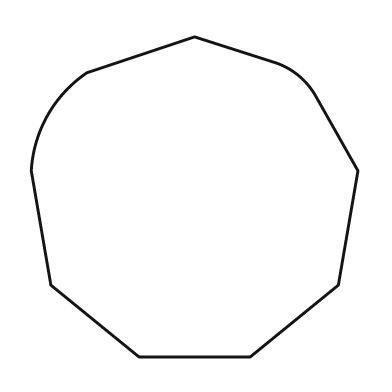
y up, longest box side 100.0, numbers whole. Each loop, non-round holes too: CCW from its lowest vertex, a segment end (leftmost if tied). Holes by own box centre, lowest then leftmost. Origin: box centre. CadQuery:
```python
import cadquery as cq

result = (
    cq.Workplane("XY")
    .moveTo(-17.0, -49.0)
    .lineTo(17.0, -49.0)
    .lineTo(44.0, -27.0)
    .lineTo(50.0, 8.0)
    .lineTo(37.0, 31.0)
    .threePointArc((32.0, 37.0), (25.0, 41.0))
    .lineTo(0.0, 49.0)
    .lineTo(-33.0, 38.0)
    .threePointArc((-45.0, 25.0), (-50.0, 8.0))
    .lineTo(-44.0, -27.0)
    .close()
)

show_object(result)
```